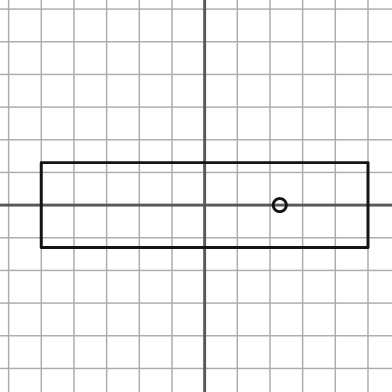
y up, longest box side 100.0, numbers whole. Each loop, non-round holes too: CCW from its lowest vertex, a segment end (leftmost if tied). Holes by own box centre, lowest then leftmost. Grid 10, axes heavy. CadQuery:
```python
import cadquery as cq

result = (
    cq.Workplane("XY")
    .moveTo(-50.0, -13.0)
    .lineTo(50.0, -13.0)
    .lineTo(50.0, 13.0)
    .lineTo(-50.0, 13.0)
    .close()
    .moveTo(23.0, 0.0)
    .circle(2.0)
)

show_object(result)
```